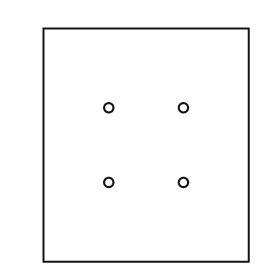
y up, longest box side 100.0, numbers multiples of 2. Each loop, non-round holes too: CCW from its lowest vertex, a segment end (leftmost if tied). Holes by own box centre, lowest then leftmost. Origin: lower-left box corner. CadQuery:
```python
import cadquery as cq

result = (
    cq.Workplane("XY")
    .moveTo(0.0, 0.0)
    .lineTo(88.0, 0.0)
    .lineTo(88.0, 100.0)
    .lineTo(0.0, 100.0)
    .close()
    .moveTo(28.0, 34.0)
    .circle(2.0)
    .moveTo(60.0, 34.0)
    .circle(2.0)
    .moveTo(28.0, 66.0)
    .circle(2.0)
    .moveTo(60.0, 66.0)
    .circle(2.0)
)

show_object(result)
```